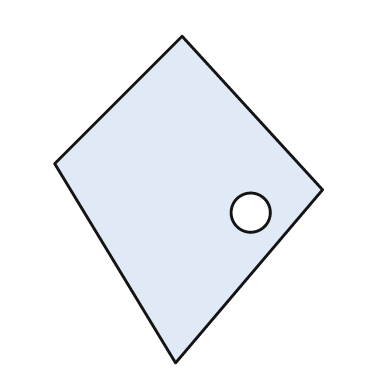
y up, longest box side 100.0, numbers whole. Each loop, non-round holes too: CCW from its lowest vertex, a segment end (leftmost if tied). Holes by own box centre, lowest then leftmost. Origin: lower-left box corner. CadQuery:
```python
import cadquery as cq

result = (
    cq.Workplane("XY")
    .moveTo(37.0, 0.0)
    .lineTo(82.0, 53.0)
    .lineTo(39.0, 100.0)
    .lineTo(0.0, 61.0)
    .close()
    .moveTo(60.0, 46.0)
    .circle(6.0)
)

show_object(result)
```